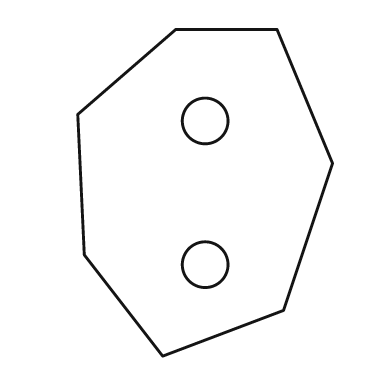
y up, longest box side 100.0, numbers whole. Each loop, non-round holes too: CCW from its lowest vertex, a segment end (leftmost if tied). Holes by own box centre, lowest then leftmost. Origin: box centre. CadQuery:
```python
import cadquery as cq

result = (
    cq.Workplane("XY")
    .moveTo(-13.0, -50.0)
    .lineTo(24.0, -36.0)
    .lineTo(39.0, 9.0)
    .lineTo(22.0, 50.0)
    .lineTo(-9.0, 50.0)
    .lineTo(-39.0, 24.0)
    .lineTo(-37.0, -19.0)
    .close()
    .moveTo(0.0, -22.0)
    .circle(7.0)
    .moveTo(0.0, 22.0)
    .circle(7.0)
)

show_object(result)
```